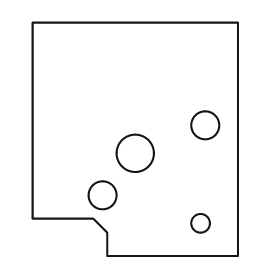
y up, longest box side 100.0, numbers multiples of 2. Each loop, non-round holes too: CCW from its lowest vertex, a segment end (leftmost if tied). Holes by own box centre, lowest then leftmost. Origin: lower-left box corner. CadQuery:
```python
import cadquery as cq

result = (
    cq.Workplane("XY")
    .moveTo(32.0, 0.0)
    .lineTo(88.0, 0.0)
    .lineTo(88.0, 100.0)
    .lineTo(0.0, 100.0)
    .lineTo(0.0, 16.0)
    .lineTo(26.0, 16.0)
    .lineTo(32.0, 10.0)
    .close()
    .moveTo(72.0, 14.0)
    .circle(4.0)
    .moveTo(30.0, 26.0)
    .circle(6.0)
    .moveTo(44.0, 44.0)
    .circle(8.0)
    .moveTo(74.0, 56.0)
    .circle(6.0)
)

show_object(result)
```